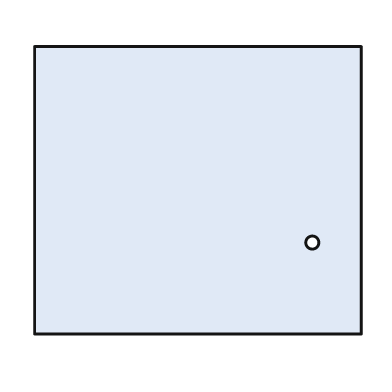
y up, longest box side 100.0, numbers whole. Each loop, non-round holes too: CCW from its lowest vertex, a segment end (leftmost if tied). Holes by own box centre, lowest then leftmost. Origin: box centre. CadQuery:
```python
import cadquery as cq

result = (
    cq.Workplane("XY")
    .moveTo(-50.0, -44.0)
    .lineTo(50.0, -44.0)
    .lineTo(50.0, 44.0)
    .lineTo(-50.0, 44.0)
    .close()
    .moveTo(35.0, -16.0)
    .circle(2.0)
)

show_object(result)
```